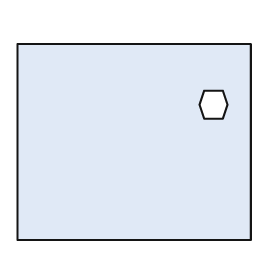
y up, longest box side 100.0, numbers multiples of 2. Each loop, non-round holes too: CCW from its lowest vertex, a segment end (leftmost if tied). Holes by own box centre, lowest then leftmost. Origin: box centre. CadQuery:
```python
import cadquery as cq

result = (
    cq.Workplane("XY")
    .moveTo(-50.0, -42.0)
    .lineTo(50.0, -42.0)
    .lineTo(50.0, 42.0)
    .lineTo(-50.0, 42.0)
    .close()
    .moveTo(30.0, 10.0)
    .lineTo(38.0, 10.0)
    .lineTo(40.0, 16.0)
    .lineTo(38.0, 22.0)
    .lineTo(30.0, 22.0)
    .lineTo(28.0, 16.0)
    .close()
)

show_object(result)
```